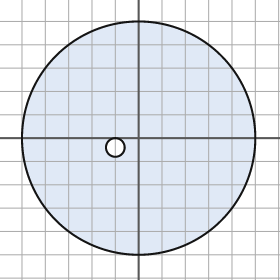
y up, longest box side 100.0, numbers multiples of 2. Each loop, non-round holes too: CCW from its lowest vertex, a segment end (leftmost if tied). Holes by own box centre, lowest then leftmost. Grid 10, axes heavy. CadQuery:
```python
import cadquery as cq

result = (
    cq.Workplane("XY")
    .moveTo(0.0, 0.0)
    .circle(50.0)
    .moveTo(-10.0, -4.0)
    .circle(4.0)
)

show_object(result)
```